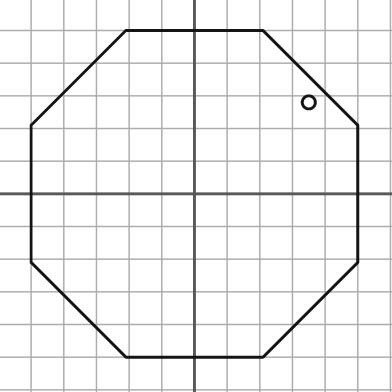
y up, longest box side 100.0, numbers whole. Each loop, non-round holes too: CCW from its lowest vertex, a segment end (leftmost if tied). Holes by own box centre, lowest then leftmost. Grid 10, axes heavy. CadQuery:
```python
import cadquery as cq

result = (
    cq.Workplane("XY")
    .moveTo(-21.0, -50.0)
    .lineTo(21.0, -50.0)
    .lineTo(50.0, -21.0)
    .lineTo(50.0, 21.0)
    .lineTo(21.0, 50.0)
    .lineTo(-21.0, 50.0)
    .lineTo(-50.0, 21.0)
    .lineTo(-50.0, -21.0)
    .close()
    .moveTo(35.0, 28.0)
    .circle(2.0)
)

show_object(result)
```